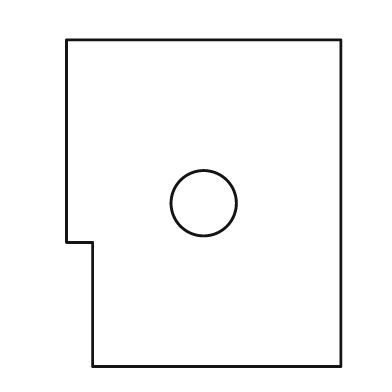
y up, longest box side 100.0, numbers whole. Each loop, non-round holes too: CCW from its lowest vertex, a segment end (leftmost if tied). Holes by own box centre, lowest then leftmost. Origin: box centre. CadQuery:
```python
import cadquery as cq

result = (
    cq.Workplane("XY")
    .moveTo(-34.0, -50.0)
    .lineTo(42.0, -50.0)
    .lineTo(42.0, 50.0)
    .lineTo(-42.0, 50.0)
    .lineTo(-42.0, -12.0)
    .lineTo(-34.0, -12.0)
    .close()
    .moveTo(0.0, 0.0)
    .circle(10.0)
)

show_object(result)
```